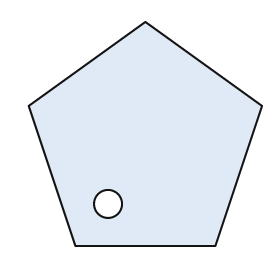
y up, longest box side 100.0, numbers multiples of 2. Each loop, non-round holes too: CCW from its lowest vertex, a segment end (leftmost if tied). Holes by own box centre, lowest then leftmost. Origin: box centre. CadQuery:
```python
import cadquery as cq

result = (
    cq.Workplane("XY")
    .moveTo(-30.0, -48.0)
    .lineTo(30.0, -48.0)
    .lineTo(50.0, 12.0)
    .lineTo(0.0, 48.0)
    .lineTo(-50.0, 12.0)
    .close()
    .moveTo(-16.0, -30.0)
    .circle(6.0)
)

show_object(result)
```